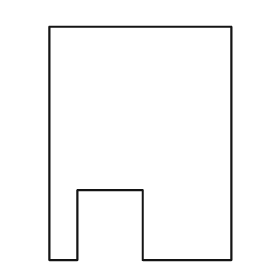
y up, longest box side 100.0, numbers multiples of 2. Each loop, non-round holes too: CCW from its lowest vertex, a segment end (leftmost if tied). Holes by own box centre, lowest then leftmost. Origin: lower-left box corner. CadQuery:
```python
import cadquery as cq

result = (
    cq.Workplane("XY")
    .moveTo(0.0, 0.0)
    .lineTo(12.0, 0.0)
    .lineTo(12.0, 30.0)
    .lineTo(40.0, 30.0)
    .lineTo(40.0, 0.0)
    .lineTo(78.0, 0.0)
    .lineTo(78.0, 100.0)
    .lineTo(0.0, 100.0)
    .close()
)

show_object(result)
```